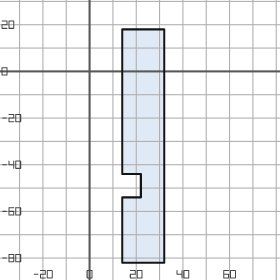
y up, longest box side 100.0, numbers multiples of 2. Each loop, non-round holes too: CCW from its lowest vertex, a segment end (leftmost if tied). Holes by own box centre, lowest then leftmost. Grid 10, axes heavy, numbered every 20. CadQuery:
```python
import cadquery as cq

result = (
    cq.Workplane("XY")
    .moveTo(14.0, -82.0)
    .lineTo(32.0, -82.0)
    .lineTo(32.0, 18.0)
    .lineTo(14.0, 18.0)
    .lineTo(14.0, -44.0)
    .lineTo(22.0, -44.0)
    .lineTo(22.0, -54.0)
    .lineTo(14.0, -54.0)
    .close()
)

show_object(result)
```